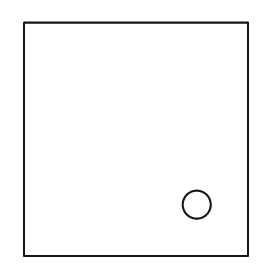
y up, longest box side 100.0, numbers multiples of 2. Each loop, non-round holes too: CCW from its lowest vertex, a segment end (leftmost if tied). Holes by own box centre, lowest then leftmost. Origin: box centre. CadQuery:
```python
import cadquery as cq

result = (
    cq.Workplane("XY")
    .moveTo(-48.0, -50.0)
    .lineTo(48.0, -50.0)
    .lineTo(48.0, 50.0)
    .lineTo(-48.0, 50.0)
    .close()
    .moveTo(26.0, -28.0)
    .circle(6.0)
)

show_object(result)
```